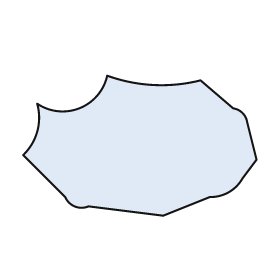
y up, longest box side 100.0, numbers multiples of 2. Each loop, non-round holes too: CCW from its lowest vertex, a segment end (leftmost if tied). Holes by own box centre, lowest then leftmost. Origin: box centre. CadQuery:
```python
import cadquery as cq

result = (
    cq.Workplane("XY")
    .moveTo(10.0, -30.0)
    .lineTo(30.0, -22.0)
    .threePointArc((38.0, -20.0), (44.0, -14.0))
    .lineTo(50.0, -6.0)
    .lineTo(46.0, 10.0)
    .threePointArc((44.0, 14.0), (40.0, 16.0))
    .lineTo(26.0, 28.0)
    .threePointArc((6.0, 26.0), (-14.0, 30.0))
    .threePointArc((-26.0, 16.0), (-44.0, 18.0))
    .threePointArc((-44.0, 6.0), (-50.0, -4.0))
    .lineTo(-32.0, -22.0)
    .threePointArc((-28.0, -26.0), (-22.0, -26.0))
    .close()
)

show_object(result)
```